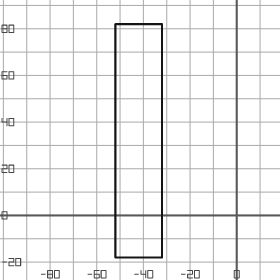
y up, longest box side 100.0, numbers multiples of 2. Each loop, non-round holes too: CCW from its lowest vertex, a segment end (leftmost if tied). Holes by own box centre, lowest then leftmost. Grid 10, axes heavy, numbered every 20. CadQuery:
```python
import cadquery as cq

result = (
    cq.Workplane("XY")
    .moveTo(-52.0, -18.0)
    .lineTo(-32.0, -18.0)
    .lineTo(-32.0, 82.0)
    .lineTo(-52.0, 82.0)
    .close()
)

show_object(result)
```